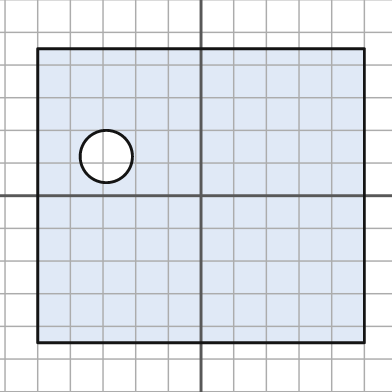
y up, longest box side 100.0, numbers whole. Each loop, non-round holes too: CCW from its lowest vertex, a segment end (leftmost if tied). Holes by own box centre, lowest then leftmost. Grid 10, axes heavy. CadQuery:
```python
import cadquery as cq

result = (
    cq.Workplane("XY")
    .moveTo(-50.0, -45.0)
    .lineTo(50.0, -45.0)
    .lineTo(50.0, 45.0)
    .lineTo(-50.0, 45.0)
    .close()
    .moveTo(-29.0, 12.0)
    .circle(8.0)
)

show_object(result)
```